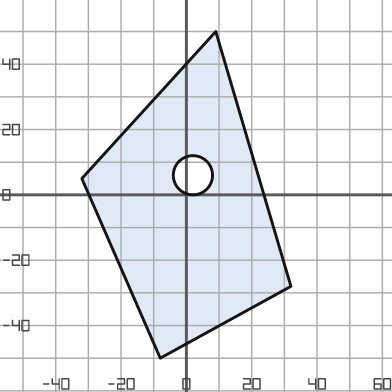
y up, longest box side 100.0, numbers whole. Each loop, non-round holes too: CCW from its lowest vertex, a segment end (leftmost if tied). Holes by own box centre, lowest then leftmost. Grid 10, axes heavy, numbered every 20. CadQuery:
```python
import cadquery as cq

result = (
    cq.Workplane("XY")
    .moveTo(-8.0, -50.0)
    .lineTo(32.0, -28.0)
    .lineTo(9.0, 50.0)
    .lineTo(-32.0, 5.0)
    .close()
    .moveTo(2.0, 6.0)
    .circle(6.0)
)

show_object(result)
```